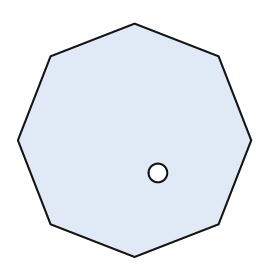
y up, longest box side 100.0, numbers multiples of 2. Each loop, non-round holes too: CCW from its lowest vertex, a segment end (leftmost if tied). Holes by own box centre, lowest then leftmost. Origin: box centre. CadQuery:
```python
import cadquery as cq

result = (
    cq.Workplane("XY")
    .moveTo(0.0, -50.0)
    .lineTo(36.0, -36.0)
    .lineTo(50.0, 0.0)
    .lineTo(36.0, 36.0)
    .lineTo(0.0, 50.0)
    .lineTo(-36.0, 36.0)
    .lineTo(-50.0, 0.0)
    .lineTo(-36.0, -36.0)
    .close()
    .moveTo(10.0, -14.0)
    .circle(4.0)
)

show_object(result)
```